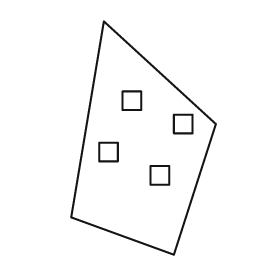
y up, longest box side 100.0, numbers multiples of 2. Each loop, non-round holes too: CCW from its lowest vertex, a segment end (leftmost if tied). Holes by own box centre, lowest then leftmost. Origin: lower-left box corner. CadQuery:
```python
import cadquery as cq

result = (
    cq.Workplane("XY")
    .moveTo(44.0, 0.0)
    .lineTo(62.0, 56.0)
    .lineTo(14.0, 100.0)
    .lineTo(0.0, 16.0)
    .close()
    .moveTo(34.0, 30.0)
    .lineTo(42.0, 30.0)
    .lineTo(42.0, 38.0)
    .lineTo(34.0, 38.0)
    .close()
    .moveTo(12.0, 40.0)
    .lineTo(20.0, 40.0)
    .lineTo(20.0, 48.0)
    .lineTo(12.0, 48.0)
    .close()
    .moveTo(44.0, 52.0)
    .lineTo(52.0, 52.0)
    .lineTo(52.0, 60.0)
    .lineTo(44.0, 60.0)
    .close()
    .moveTo(22.0, 62.0)
    .lineTo(30.0, 62.0)
    .lineTo(30.0, 70.0)
    .lineTo(22.0, 70.0)
    .close()
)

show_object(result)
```